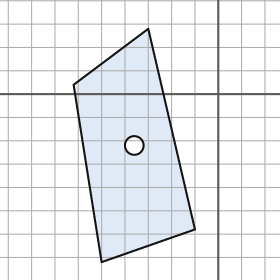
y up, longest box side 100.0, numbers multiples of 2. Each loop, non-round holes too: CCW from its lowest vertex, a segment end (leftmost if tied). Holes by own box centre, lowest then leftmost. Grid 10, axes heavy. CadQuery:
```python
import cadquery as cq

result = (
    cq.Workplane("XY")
    .moveTo(-50.0, -72.0)
    .lineTo(-10.0, -58.0)
    .lineTo(-30.0, 28.0)
    .lineTo(-62.0, 4.0)
    .close()
    .moveTo(-36.0, -22.0)
    .circle(4.0)
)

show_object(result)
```